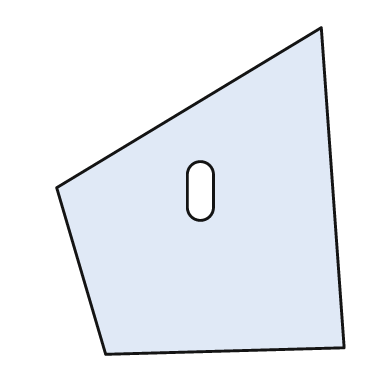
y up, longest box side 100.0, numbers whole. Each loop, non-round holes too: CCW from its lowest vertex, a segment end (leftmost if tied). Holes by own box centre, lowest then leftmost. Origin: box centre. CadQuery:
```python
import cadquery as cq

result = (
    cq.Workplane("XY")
    .moveTo(-29.0, -50.0)
    .lineTo(44.0, -48.0)
    .lineTo(37.0, 50.0)
    .lineTo(-44.0, 1.0)
    .close()
    .moveTo(-4.0, -5.0)
    .threePointArc((0.0, -9.0), (4.0, -5.0))
    .lineTo(4.0, 5.0)
    .threePointArc((0.0, 9.0), (-4.0, 5.0))
    .close()
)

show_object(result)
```